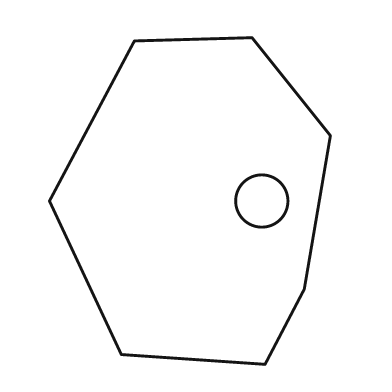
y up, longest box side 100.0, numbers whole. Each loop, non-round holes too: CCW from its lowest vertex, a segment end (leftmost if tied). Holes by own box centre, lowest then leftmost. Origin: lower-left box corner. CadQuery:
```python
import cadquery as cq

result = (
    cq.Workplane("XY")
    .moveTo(66.0, 0.0)
    .lineTo(78.0, 23.0)
    .lineTo(86.0, 70.0)
    .lineTo(62.0, 100.0)
    .lineTo(26.0, 99.0)
    .lineTo(0.0, 50.0)
    .lineTo(22.0, 3.0)
    .close()
    .moveTo(65.0, 50.0)
    .circle(8.0)
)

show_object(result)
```